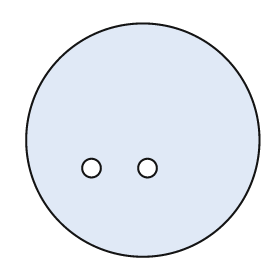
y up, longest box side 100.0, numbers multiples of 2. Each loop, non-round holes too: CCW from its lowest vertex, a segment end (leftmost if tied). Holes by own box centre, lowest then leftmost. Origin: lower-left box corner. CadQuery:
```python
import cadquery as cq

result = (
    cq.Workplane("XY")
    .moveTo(50.0, 50.0)
    .circle(50.0)
    .moveTo(28.0, 38.0)
    .circle(4.0)
    .moveTo(52.0, 38.0)
    .circle(4.0)
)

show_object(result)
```